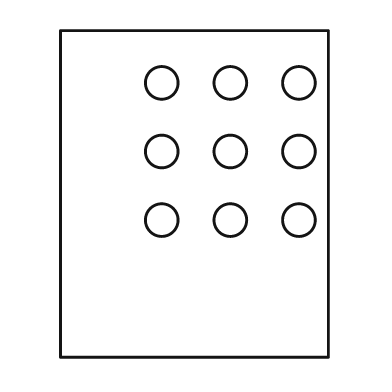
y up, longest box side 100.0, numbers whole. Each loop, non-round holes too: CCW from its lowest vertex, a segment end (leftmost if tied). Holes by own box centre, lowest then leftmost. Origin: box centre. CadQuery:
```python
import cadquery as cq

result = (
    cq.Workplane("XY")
    .moveTo(-41.0, -50.0)
    .lineTo(41.0, -50.0)
    .lineTo(41.0, 50.0)
    .lineTo(-41.0, 50.0)
    .close()
    .moveTo(-10.0, -8.0)
    .circle(5.0)
    .moveTo(11.0, -8.0)
    .circle(5.0)
    .moveTo(32.0, -8.0)
    .circle(5.0)
    .moveTo(-10.0, 13.0)
    .circle(5.0)
    .moveTo(11.0, 13.0)
    .circle(5.0)
    .moveTo(32.0, 13.0)
    .circle(5.0)
    .moveTo(-10.0, 34.0)
    .circle(5.0)
    .moveTo(11.0, 34.0)
    .circle(5.0)
    .moveTo(32.0, 34.0)
    .circle(5.0)
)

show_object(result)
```